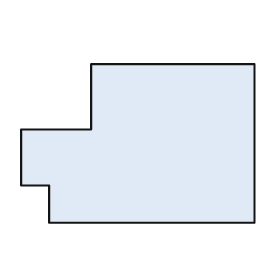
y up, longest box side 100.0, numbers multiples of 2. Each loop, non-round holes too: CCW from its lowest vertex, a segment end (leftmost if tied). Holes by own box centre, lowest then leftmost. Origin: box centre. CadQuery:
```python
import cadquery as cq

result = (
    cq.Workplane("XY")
    .moveTo(-38.0, -34.0)
    .lineTo(50.0, -34.0)
    .lineTo(50.0, 34.0)
    .lineTo(-20.0, 34.0)
    .lineTo(-20.0, 6.0)
    .lineTo(-50.0, 6.0)
    .lineTo(-50.0, -18.0)
    .lineTo(-38.0, -18.0)
    .close()
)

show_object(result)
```